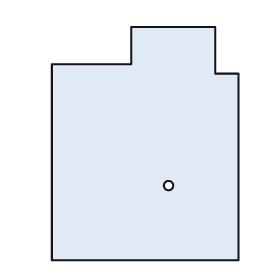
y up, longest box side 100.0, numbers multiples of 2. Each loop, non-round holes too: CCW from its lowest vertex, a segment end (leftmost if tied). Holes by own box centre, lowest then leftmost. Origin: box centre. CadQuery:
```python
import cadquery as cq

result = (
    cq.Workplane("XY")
    .moveTo(-40.0, -50.0)
    .lineTo(40.0, -50.0)
    .lineTo(40.0, 30.0)
    .lineTo(30.0, 30.0)
    .lineTo(30.0, 50.0)
    .lineTo(-6.0, 50.0)
    .lineTo(-6.0, 34.0)
    .lineTo(-40.0, 34.0)
    .close()
    .moveTo(10.0, -18.0)
    .circle(2.0)
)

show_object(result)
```